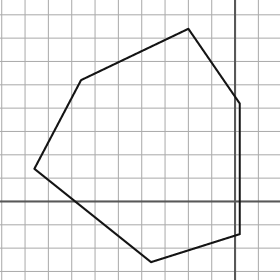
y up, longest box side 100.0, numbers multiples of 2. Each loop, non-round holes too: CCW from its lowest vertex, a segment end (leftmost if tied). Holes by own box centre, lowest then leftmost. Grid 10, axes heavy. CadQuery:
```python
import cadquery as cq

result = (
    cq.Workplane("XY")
    .moveTo(-36.0, -26.0)
    .lineTo(2.0, -14.0)
    .lineTo(2.0, 42.0)
    .lineTo(-20.0, 74.0)
    .lineTo(-66.0, 52.0)
    .lineTo(-86.0, 14.0)
    .close()
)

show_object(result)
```